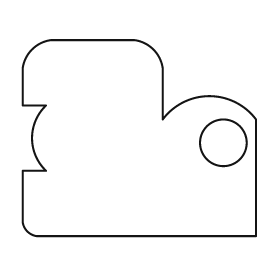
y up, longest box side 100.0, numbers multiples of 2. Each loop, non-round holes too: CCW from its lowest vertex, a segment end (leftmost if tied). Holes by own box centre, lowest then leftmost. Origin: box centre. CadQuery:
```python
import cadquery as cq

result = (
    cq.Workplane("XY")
    .moveTo(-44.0, -42.0)
    .lineTo(50.0, -42.0)
    .lineTo(50.0, 8.0)
    .threePointArc((30.0, 18.0), (10.0, 8.0))
    .lineTo(10.0, 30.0)
    .threePointArc((6.0, 38.0), (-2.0, 42.0))
    .lineTo(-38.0, 42.0)
    .threePointArc((-46.0, 38.0), (-50.0, 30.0))
    .lineTo(-50.0, 14.0)
    .lineTo(-40.0, 14.0)
    .threePointArc((-46.0, 0.0), (-40.0, -14.0))
    .lineTo(-50.0, -14.0)
    .lineTo(-50.0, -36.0)
    .threePointArc((-48.0, -40.0), (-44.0, -42.0))
    .close()
    .moveTo(36.0, -2.0)
    .circle(10.0)
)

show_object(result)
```